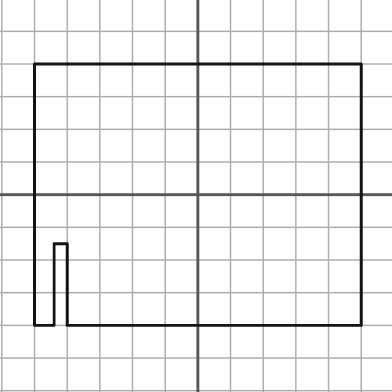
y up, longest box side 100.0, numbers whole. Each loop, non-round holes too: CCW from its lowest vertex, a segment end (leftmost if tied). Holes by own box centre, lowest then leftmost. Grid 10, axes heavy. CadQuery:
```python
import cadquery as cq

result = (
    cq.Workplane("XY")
    .moveTo(-50.0, -40.0)
    .lineTo(-44.0, -40.0)
    .lineTo(-44.0, -15.0)
    .lineTo(-40.0, -15.0)
    .lineTo(-40.0, -40.0)
    .lineTo(50.0, -40.0)
    .lineTo(50.0, 40.0)
    .lineTo(-50.0, 40.0)
    .close()
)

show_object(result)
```